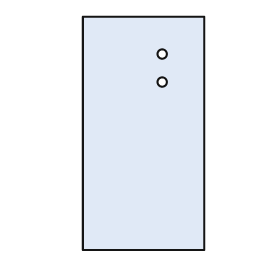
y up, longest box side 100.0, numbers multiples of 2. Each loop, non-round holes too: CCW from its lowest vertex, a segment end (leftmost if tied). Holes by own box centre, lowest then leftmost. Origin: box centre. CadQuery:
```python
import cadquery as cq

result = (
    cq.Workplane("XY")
    .moveTo(-26.0, -50.0)
    .lineTo(26.0, -50.0)
    .lineTo(26.0, 50.0)
    .lineTo(-26.0, 50.0)
    .close()
    .moveTo(8.0, 22.0)
    .circle(2.0)
    .moveTo(8.0, 34.0)
    .circle(2.0)
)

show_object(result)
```